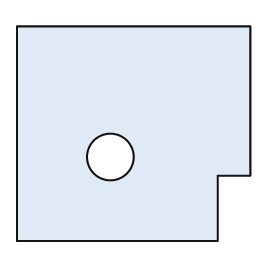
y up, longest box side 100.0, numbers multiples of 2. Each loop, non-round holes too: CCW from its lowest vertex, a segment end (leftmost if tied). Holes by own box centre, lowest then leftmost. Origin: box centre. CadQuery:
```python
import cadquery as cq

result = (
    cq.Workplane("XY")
    .moveTo(-50.0, -46.0)
    .lineTo(36.0, -46.0)
    .lineTo(36.0, -18.0)
    .lineTo(50.0, -18.0)
    .lineTo(50.0, 46.0)
    .lineTo(-50.0, 46.0)
    .close()
    .moveTo(-10.0, -10.0)
    .circle(10.0)
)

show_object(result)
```